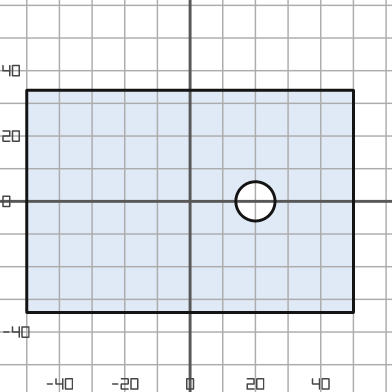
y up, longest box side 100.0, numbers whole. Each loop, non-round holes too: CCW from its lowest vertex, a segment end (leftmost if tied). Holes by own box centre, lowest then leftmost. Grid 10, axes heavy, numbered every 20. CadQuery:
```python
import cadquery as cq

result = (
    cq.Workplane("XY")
    .moveTo(-50.0, -34.0)
    .lineTo(50.0, -34.0)
    .lineTo(50.0, 34.0)
    .lineTo(-50.0, 34.0)
    .close()
    .moveTo(20.0, 0.0)
    .circle(6.0)
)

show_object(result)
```